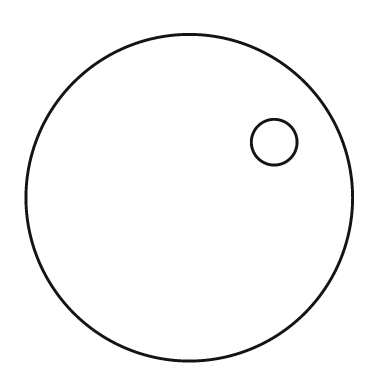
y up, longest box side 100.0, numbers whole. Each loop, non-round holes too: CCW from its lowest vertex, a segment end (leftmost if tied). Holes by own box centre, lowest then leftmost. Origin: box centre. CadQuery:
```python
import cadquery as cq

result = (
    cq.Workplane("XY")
    .moveTo(0.0, 0.0)
    .circle(50.0)
    .moveTo(26.0, 17.0)
    .circle(7.0)
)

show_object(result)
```